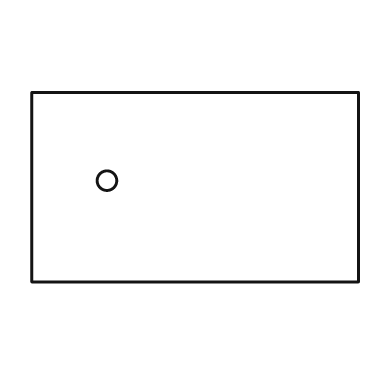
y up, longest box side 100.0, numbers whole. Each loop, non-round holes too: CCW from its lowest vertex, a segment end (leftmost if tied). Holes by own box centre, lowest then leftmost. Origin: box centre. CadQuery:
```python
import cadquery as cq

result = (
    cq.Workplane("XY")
    .moveTo(-50.0, -29.0)
    .lineTo(50.0, -29.0)
    .lineTo(50.0, 29.0)
    .lineTo(-50.0, 29.0)
    .close()
    .moveTo(-27.0, 2.0)
    .circle(3.0)
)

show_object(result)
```